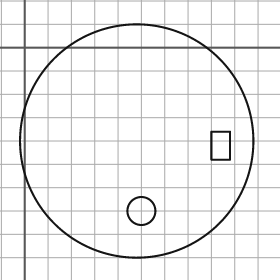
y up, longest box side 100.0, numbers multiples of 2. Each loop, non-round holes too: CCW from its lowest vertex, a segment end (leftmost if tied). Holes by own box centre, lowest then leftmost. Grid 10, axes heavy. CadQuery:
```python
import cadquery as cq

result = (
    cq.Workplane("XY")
    .moveTo(48.0, -40.0)
    .circle(50.0)
    .moveTo(50.0, -70.0)
    .circle(6.0)
    .moveTo(80.0, -48.0)
    .lineTo(88.0, -48.0)
    .lineTo(88.0, -36.0)
    .lineTo(80.0, -36.0)
    .close()
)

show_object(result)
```